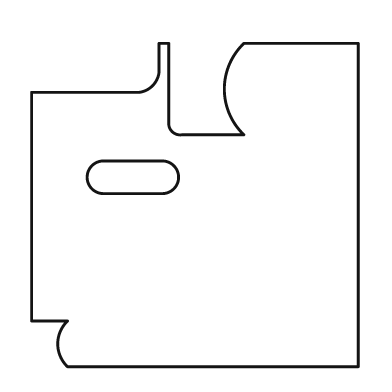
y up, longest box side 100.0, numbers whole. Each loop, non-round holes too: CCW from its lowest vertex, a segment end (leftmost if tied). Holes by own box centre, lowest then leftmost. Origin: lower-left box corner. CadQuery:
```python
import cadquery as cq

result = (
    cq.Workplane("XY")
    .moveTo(11.0, 0.0)
    .lineTo(100.0, 0.0)
    .lineTo(100.0, 99.0)
    .lineTo(65.0, 99.0)
    .threePointArc((59.0, 85.0), (65.0, 71.0))
    .lineTo(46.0, 71.0)
    .threePointArc((43.0, 72.0), (42.0, 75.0))
    .lineTo(42.0, 99.0)
    .lineTo(39.0, 99.0)
    .lineTo(39.0, 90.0)
    .threePointArc((37.0, 86.0), (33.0, 84.0))
    .lineTo(0.0, 84.0)
    .lineTo(0.0, 14.0)
    .lineTo(11.0, 14.0)
    .threePointArc((8.0, 7.0), (11.0, 0.0))
    .close()
    .moveTo(22.0, 53.0)
    .lineTo(40.0, 53.0)
    .threePointArc((45.0, 58.0), (40.0, 63.0))
    .lineTo(22.0, 63.0)
    .threePointArc((17.0, 58.0), (22.0, 53.0))
    .close()
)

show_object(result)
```